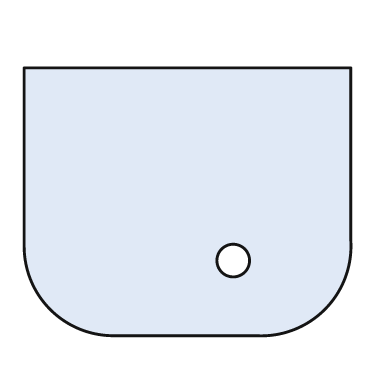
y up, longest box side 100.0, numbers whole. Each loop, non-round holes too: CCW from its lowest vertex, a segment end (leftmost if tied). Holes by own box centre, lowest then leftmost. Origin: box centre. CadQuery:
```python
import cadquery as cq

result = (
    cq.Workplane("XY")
    .moveTo(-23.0, -41.0)
    .lineTo(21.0, -41.0)
    .threePointArc((42.0, -33.0), (50.0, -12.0))
    .lineTo(50.0, 41.0)
    .lineTo(-50.0, 41.0)
    .lineTo(-50.0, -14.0)
    .threePointArc((-42.0, -33.0), (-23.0, -41.0))
    .close()
    .moveTo(14.0, -18.0)
    .circle(5.0)
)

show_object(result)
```